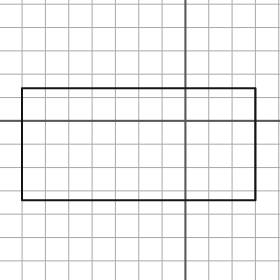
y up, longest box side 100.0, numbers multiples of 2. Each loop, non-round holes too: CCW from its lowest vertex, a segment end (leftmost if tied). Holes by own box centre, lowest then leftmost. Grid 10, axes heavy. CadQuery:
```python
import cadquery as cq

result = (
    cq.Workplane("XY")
    .moveTo(-70.0, -34.0)
    .lineTo(30.0, -34.0)
    .lineTo(30.0, 14.0)
    .lineTo(-70.0, 14.0)
    .close()
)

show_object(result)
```